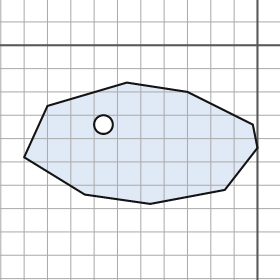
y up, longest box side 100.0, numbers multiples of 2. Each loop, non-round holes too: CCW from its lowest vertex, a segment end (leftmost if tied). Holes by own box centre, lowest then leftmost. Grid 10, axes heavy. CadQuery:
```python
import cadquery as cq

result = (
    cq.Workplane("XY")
    .moveTo(-46.0, -68.0)
    .lineTo(-14.0, -62.0)
    .lineTo(0.0, -44.0)
    .lineTo(-2.0, -34.0)
    .lineTo(-30.0, -20.0)
    .lineTo(-56.0, -16.0)
    .lineTo(-90.0, -26.0)
    .lineTo(-100.0, -48.0)
    .lineTo(-74.0, -64.0)
    .close()
    .moveTo(-66.0, -34.0)
    .circle(4.0)
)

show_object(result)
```